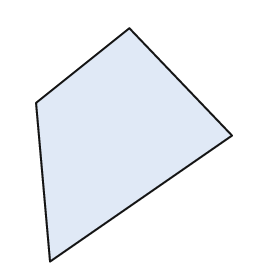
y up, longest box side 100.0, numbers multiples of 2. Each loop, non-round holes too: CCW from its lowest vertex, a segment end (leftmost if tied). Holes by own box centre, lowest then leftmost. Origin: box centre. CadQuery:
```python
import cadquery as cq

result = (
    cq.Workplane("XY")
    .moveTo(-36.0, -50.0)
    .lineTo(42.0, 4.0)
    .lineTo(-2.0, 50.0)
    .lineTo(-42.0, 18.0)
    .close()
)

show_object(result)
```